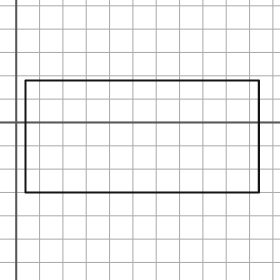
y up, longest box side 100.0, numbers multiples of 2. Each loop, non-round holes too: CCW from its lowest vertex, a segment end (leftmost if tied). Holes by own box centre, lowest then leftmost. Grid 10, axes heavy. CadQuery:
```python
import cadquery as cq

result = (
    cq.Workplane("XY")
    .moveTo(4.0, -30.0)
    .lineTo(104.0, -30.0)
    .lineTo(104.0, 18.0)
    .lineTo(4.0, 18.0)
    .close()
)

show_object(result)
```